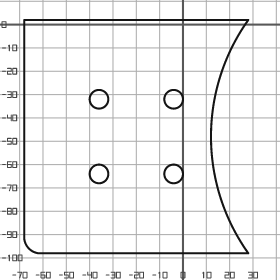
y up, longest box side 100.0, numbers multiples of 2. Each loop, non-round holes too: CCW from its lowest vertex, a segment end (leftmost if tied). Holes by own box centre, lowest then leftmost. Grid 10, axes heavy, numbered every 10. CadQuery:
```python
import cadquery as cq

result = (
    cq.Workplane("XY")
    .moveTo(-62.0, -98.0)
    .lineTo(28.0, -98.0)
    .threePointArc((12.0, -48.0), (28.0, 2.0))
    .lineTo(-68.0, 2.0)
    .lineTo(-68.0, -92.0)
    .threePointArc((-66.0, -96.0), (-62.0, -98.0))
    .close()
    .moveTo(-36.0, -64.0)
    .circle(4.0)
    .moveTo(-4.0, -64.0)
    .circle(4.0)
    .moveTo(-36.0, -32.0)
    .circle(4.0)
    .moveTo(-4.0, -32.0)
    .circle(4.0)
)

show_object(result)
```